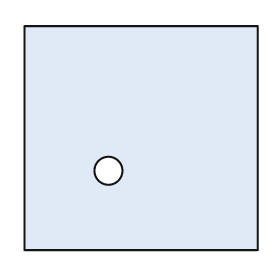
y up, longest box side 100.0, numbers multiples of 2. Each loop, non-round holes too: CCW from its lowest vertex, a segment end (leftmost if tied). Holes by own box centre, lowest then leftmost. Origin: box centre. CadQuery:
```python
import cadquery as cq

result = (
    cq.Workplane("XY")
    .moveTo(-50.0, -48.0)
    .lineTo(50.0, -48.0)
    .lineTo(50.0, 48.0)
    .lineTo(-50.0, 48.0)
    .close()
    .moveTo(-14.0, -14.0)
    .circle(6.0)
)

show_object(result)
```